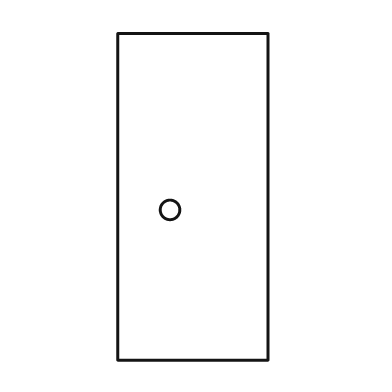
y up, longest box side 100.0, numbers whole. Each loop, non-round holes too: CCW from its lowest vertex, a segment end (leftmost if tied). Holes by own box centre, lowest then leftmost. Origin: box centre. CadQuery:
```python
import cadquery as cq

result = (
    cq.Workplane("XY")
    .moveTo(-23.0, -50.0)
    .lineTo(23.0, -50.0)
    .lineTo(23.0, 50.0)
    .lineTo(-23.0, 50.0)
    .close()
    .moveTo(-7.0, -4.0)
    .circle(3.0)
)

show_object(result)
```